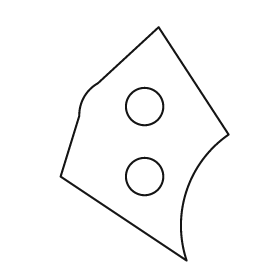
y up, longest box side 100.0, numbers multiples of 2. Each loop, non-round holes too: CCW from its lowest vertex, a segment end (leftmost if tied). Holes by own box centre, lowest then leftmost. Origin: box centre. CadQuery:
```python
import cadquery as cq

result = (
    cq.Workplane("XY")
    .moveTo(18.0, -50.0)
    .threePointArc((18.0, -20.0), (36.0, 4.0))
    .lineTo(6.0, 50.0)
    .lineTo(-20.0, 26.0)
    .threePointArc((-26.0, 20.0), (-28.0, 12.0))
    .lineTo(-36.0, -14.0)
    .close()
    .moveTo(0.0, -14.0)
    .circle(8.0)
    .moveTo(0.0, 16.0)
    .circle(8.0)
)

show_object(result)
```